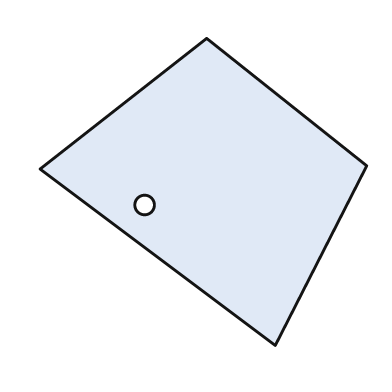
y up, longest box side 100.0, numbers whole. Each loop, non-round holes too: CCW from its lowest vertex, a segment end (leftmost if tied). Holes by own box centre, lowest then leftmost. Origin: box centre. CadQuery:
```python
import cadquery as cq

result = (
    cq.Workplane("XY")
    .moveTo(22.0, -47.0)
    .lineTo(50.0, 8.0)
    .lineTo(1.0, 47.0)
    .lineTo(-50.0, 7.0)
    .close()
    .moveTo(-18.0, -4.0)
    .circle(3.0)
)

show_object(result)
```